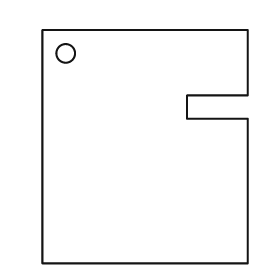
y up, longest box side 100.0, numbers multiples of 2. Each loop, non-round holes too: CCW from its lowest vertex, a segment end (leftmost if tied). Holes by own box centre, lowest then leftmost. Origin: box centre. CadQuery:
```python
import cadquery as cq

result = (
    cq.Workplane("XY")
    .moveTo(-44.0, -50.0)
    .lineTo(44.0, -50.0)
    .lineTo(44.0, 12.0)
    .lineTo(18.0, 12.0)
    .lineTo(18.0, 22.0)
    .lineTo(44.0, 22.0)
    .lineTo(44.0, 50.0)
    .lineTo(-44.0, 50.0)
    .close()
    .moveTo(-34.0, 40.0)
    .circle(4.0)
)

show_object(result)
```